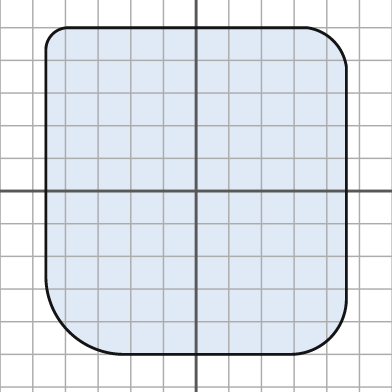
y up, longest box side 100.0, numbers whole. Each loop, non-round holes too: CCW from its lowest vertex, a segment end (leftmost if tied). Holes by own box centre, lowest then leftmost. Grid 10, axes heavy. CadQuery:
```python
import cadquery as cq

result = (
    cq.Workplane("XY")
    .moveTo(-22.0, -50.0)
    .lineTo(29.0, -50.0)
    .threePointArc((41.0, -45.0), (46.0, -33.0))
    .lineTo(46.0, 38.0)
    .threePointArc((42.0, 46.0), (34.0, 50.0))
    .lineTo(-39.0, 50.0)
    .threePointArc((-44.0, 48.0), (-46.0, 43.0))
    .lineTo(-46.0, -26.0)
    .threePointArc((-39.0, -43.0), (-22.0, -50.0))
    .close()
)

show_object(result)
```